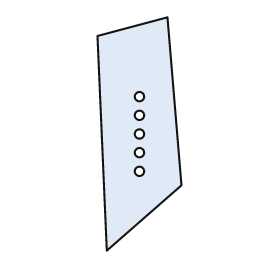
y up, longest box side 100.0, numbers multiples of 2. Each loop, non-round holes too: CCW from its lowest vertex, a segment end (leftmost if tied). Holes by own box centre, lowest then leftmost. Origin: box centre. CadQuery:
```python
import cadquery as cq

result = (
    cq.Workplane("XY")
    .moveTo(-14.0, -50.0)
    .lineTo(18.0, -22.0)
    .lineTo(12.0, 50.0)
    .lineTo(-18.0, 42.0)
    .close()
    .moveTo(0.0, -16.0)
    .circle(2.0)
    .moveTo(0.0, -8.0)
    .circle(2.0)
    .moveTo(0.0, 0.0)
    .circle(2.0)
    .moveTo(0.0, 8.0)
    .circle(2.0)
    .moveTo(0.0, 16.0)
    .circle(2.0)
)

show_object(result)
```